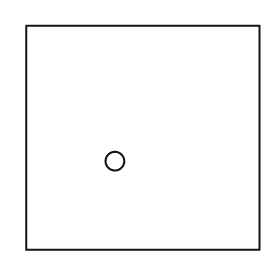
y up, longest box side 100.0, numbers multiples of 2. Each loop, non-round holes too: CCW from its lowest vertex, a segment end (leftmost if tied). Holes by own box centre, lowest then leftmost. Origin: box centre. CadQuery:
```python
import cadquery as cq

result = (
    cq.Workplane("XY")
    .moveTo(-50.0, -48.0)
    .lineTo(50.0, -48.0)
    .lineTo(50.0, 48.0)
    .lineTo(-50.0, 48.0)
    .close()
    .moveTo(-12.0, -10.0)
    .circle(4.0)
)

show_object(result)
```